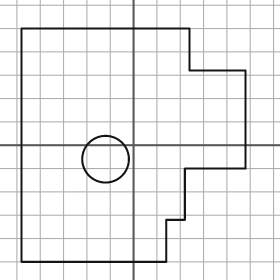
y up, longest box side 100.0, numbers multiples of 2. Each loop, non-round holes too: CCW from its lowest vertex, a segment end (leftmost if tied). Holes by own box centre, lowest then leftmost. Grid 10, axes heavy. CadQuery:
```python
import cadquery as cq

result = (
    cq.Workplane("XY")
    .moveTo(-48.0, -50.0)
    .lineTo(14.0, -50.0)
    .lineTo(14.0, -32.0)
    .lineTo(22.0, -32.0)
    .lineTo(22.0, -10.0)
    .lineTo(48.0, -10.0)
    .lineTo(48.0, 32.0)
    .lineTo(24.0, 32.0)
    .lineTo(24.0, 50.0)
    .lineTo(-48.0, 50.0)
    .close()
    .moveTo(-12.0, -6.0)
    .circle(10.0)
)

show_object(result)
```